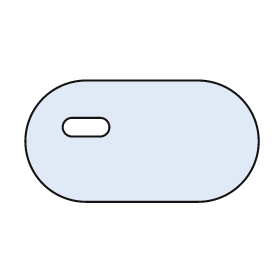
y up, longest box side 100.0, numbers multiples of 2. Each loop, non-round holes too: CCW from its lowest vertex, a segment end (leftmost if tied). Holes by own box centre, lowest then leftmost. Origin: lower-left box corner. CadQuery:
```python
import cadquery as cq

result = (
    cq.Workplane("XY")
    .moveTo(26.0, 0.0)
    .lineTo(74.0, 0.0)
    .threePointArc((100.0, 26.0), (74.0, 52.0))
    .lineTo(26.0, 52.0)
    .threePointArc((0.0, 26.0), (26.0, 0.0))
    .close()
    .moveTo(20.0, 28.0)
    .lineTo(32.0, 28.0)
    .threePointArc((36.0, 32.0), (32.0, 36.0))
    .lineTo(20.0, 36.0)
    .threePointArc((16.0, 32.0), (20.0, 28.0))
    .close()
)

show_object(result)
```